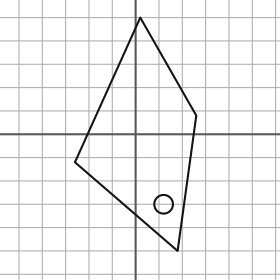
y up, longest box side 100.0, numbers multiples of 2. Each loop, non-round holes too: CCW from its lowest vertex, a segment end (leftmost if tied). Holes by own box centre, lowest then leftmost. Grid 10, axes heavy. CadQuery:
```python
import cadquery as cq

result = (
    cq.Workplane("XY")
    .moveTo(18.0, -50.0)
    .lineTo(26.0, 8.0)
    .lineTo(2.0, 50.0)
    .lineTo(-26.0, -12.0)
    .close()
    .moveTo(12.0, -30.0)
    .circle(4.0)
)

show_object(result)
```